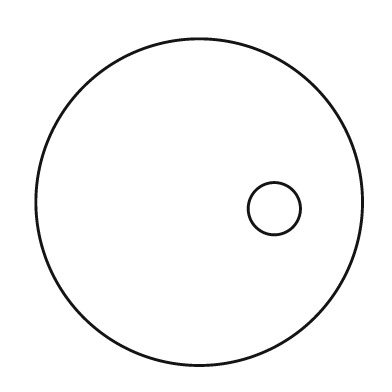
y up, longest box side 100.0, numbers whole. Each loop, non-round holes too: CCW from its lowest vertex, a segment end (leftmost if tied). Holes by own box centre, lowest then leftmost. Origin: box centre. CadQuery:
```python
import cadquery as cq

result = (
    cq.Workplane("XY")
    .moveTo(0.0, 0.0)
    .circle(50.0)
    .moveTo(23.0, -2.0)
    .circle(8.0)
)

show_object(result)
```